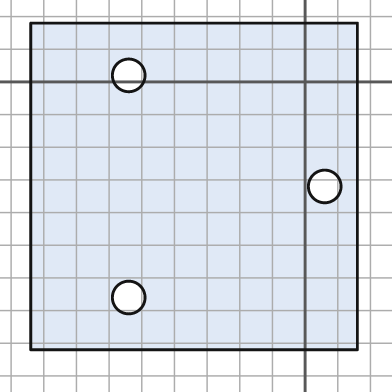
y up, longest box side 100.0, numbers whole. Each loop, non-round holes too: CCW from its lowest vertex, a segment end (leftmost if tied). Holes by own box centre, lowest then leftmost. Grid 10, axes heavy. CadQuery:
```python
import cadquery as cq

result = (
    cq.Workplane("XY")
    .moveTo(-84.0, -82.0)
    .lineTo(16.0, -82.0)
    .lineTo(16.0, 18.0)
    .lineTo(-84.0, 18.0)
    .close()
    .moveTo(-54.0, -66.0)
    .circle(5.0)
    .moveTo(6.0, -32.0)
    .circle(5.0)
    .moveTo(-54.0, 2.0)
    .circle(5.0)
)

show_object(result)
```